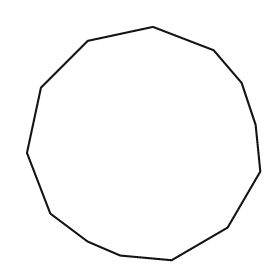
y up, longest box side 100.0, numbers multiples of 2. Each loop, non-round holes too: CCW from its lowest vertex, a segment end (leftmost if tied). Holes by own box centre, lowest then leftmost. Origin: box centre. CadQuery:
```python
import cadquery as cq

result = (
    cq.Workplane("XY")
    .moveTo(12.0, -50.0)
    .lineTo(36.0, -36.0)
    .lineTo(50.0, -12.0)
    .lineTo(48.0, 8.0)
    .lineTo(42.0, 26.0)
    .lineTo(30.0, 40.0)
    .lineTo(4.0, 50.0)
    .lineTo(-24.0, 44.0)
    .lineTo(-44.0, 24.0)
    .lineTo(-50.0, -4.0)
    .lineTo(-40.0, -30.0)
    .lineTo(-24.0, -42.0)
    .lineTo(-10.0, -48.0)
    .close()
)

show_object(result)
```